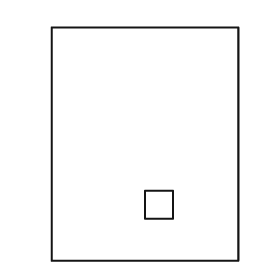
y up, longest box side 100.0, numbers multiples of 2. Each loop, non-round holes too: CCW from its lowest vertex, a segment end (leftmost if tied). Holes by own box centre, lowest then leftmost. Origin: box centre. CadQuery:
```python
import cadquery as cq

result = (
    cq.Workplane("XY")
    .moveTo(-40.0, -50.0)
    .lineTo(40.0, -50.0)
    .lineTo(40.0, 50.0)
    .lineTo(-40.0, 50.0)
    .close()
    .moveTo(0.0, -32.0)
    .lineTo(12.0, -32.0)
    .lineTo(12.0, -20.0)
    .lineTo(0.0, -20.0)
    .close()
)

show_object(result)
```